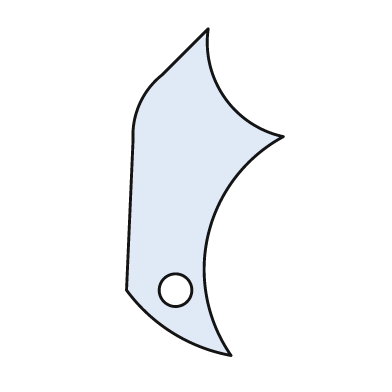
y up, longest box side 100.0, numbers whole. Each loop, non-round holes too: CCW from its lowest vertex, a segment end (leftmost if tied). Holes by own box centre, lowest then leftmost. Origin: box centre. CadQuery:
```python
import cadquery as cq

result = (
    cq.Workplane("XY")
    .moveTo(8.0, -50.0)
    .threePointArc((1.0, -13.0), (24.0, 17.0))
    .threePointArc((6.0, 29.0), (1.0, 50.0))
    .lineTo(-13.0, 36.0)
    .threePointArc((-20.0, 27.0), (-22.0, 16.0))
    .lineTo(-24.0, -30.0)
    .threePointArc((-10.0, -43.0), (8.0, -50.0))
    .close()
    .moveTo(-9.0, -30.0)
    .circle(5.0)
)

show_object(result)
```